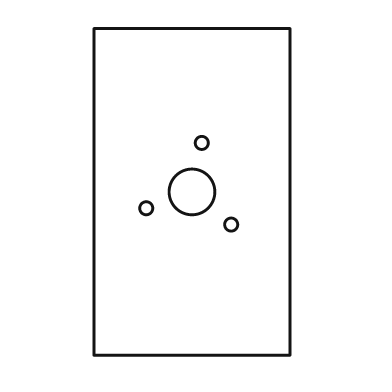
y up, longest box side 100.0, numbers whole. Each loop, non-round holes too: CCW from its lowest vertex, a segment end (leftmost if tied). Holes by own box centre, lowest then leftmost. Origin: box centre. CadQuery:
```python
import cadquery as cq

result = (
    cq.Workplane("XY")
    .moveTo(-30.0, -50.0)
    .lineTo(30.0, -50.0)
    .lineTo(30.0, 50.0)
    .lineTo(-30.0, 50.0)
    .close()
    .moveTo(12.0, -10.0)
    .circle(2.0)
    .moveTo(-14.0, -5.0)
    .circle(2.0)
    .moveTo(0.0, 0.0)
    .circle(7.0)
    .moveTo(3.0, 15.0)
    .circle(2.0)
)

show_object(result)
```